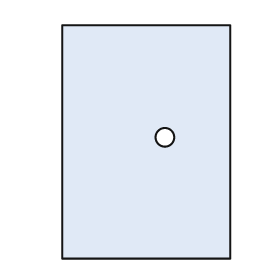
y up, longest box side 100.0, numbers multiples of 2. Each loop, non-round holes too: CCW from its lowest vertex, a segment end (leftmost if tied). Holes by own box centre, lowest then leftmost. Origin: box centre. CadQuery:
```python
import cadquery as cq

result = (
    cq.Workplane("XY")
    .moveTo(-36.0, -50.0)
    .lineTo(36.0, -50.0)
    .lineTo(36.0, 50.0)
    .lineTo(-36.0, 50.0)
    .close()
    .moveTo(8.0, 2.0)
    .circle(4.0)
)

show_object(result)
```